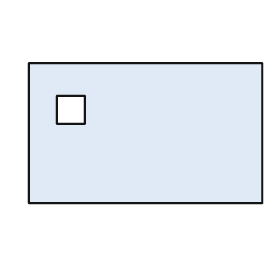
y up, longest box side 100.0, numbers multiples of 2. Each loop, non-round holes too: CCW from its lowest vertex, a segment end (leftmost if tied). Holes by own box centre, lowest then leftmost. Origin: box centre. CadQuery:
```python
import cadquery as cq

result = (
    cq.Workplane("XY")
    .moveTo(-50.0, -30.0)
    .lineTo(50.0, -30.0)
    .lineTo(50.0, 30.0)
    .lineTo(-50.0, 30.0)
    .close()
    .moveTo(-38.0, 4.0)
    .lineTo(-26.0, 4.0)
    .lineTo(-26.0, 16.0)
    .lineTo(-38.0, 16.0)
    .close()
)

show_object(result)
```